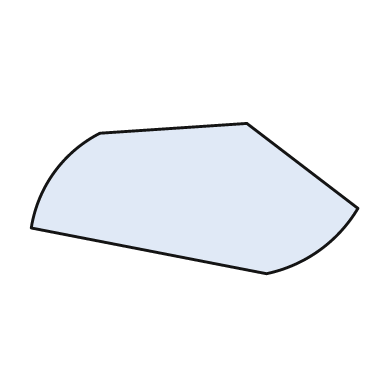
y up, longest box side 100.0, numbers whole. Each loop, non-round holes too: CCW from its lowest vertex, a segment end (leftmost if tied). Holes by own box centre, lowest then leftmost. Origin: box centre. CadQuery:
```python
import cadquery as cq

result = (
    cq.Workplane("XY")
    .moveTo(22.0, -23.0)
    .threePointArc((38.0, -16.0), (50.0, -3.0))
    .lineTo(16.0, 23.0)
    .lineTo(-29.0, 20.0)
    .threePointArc((-43.0, 8.0), (-50.0, -9.0))
    .close()
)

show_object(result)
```